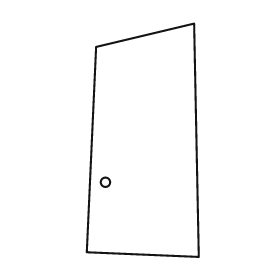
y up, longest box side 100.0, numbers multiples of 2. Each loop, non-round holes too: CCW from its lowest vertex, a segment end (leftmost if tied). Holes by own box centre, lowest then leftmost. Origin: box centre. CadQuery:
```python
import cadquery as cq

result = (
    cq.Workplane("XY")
    .moveTo(24.0, -50.0)
    .lineTo(22.0, 50.0)
    .lineTo(-20.0, 40.0)
    .lineTo(-24.0, -48.0)
    .close()
    .moveTo(-16.0, -18.0)
    .circle(2.0)
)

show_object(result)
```